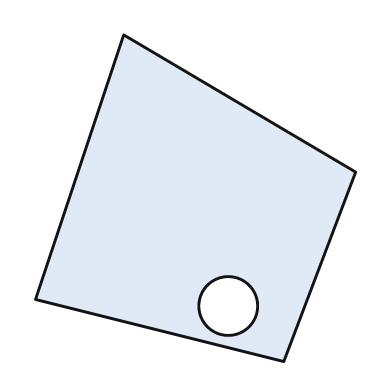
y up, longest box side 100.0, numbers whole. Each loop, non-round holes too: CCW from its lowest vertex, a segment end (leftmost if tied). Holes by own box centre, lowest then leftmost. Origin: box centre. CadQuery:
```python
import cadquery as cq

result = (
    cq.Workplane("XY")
    .moveTo(27.0, -50.0)
    .lineTo(49.0, 8.0)
    .lineTo(-22.0, 50.0)
    .lineTo(-49.0, -31.0)
    .close()
    .moveTo(10.0, -33.0)
    .circle(9.0)
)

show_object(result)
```